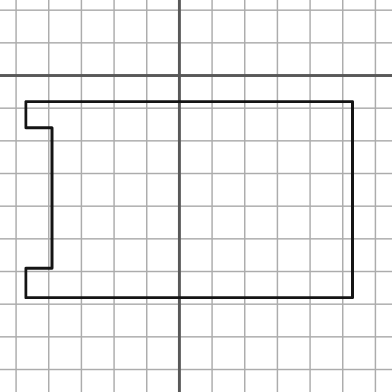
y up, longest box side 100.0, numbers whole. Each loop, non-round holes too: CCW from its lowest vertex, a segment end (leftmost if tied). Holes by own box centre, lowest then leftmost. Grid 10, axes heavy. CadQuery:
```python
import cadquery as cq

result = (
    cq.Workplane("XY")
    .moveTo(-47.0, -68.0)
    .lineTo(53.0, -68.0)
    .lineTo(53.0, -8.0)
    .lineTo(-47.0, -8.0)
    .lineTo(-47.0, -16.0)
    .lineTo(-39.0, -16.0)
    .lineTo(-39.0, -59.0)
    .lineTo(-47.0, -59.0)
    .close()
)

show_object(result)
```